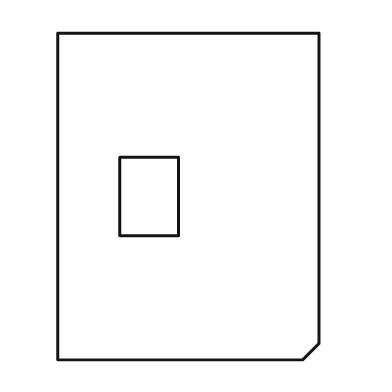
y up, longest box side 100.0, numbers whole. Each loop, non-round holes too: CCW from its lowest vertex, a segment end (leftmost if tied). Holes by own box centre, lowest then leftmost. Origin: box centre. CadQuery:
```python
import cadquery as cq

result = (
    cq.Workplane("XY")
    .moveTo(-40.0, -50.0)
    .lineTo(35.0, -50.0)
    .lineTo(40.0, -45.0)
    .lineTo(40.0, 50.0)
    .lineTo(-40.0, 50.0)
    .close()
    .moveTo(-21.0, -12.0)
    .lineTo(-3.0, -12.0)
    .lineTo(-3.0, 12.0)
    .lineTo(-21.0, 12.0)
    .close()
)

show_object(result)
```